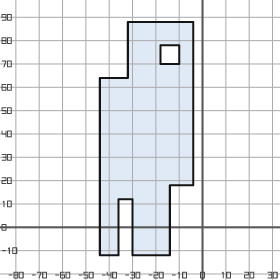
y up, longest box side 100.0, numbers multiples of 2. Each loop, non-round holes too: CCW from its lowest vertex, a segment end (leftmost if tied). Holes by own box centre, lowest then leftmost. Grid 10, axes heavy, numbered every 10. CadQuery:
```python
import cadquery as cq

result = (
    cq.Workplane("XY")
    .moveTo(-44.0, -12.0)
    .lineTo(-36.0, -12.0)
    .lineTo(-36.0, 12.0)
    .lineTo(-30.0, 12.0)
    .lineTo(-30.0, -12.0)
    .lineTo(-14.0, -12.0)
    .lineTo(-14.0, 18.0)
    .lineTo(-4.0, 18.0)
    .lineTo(-4.0, 88.0)
    .lineTo(-32.0, 88.0)
    .lineTo(-32.0, 64.0)
    .lineTo(-44.0, 64.0)
    .close()
    .moveTo(-18.0, 70.0)
    .lineTo(-10.0, 70.0)
    .lineTo(-10.0, 78.0)
    .lineTo(-18.0, 78.0)
    .close()
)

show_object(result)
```